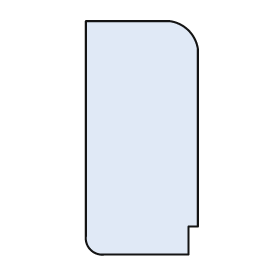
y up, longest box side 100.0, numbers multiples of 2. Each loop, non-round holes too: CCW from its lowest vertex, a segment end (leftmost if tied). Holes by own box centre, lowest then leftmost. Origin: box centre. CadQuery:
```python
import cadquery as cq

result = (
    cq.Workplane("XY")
    .moveTo(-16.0, -50.0)
    .lineTo(20.0, -50.0)
    .lineTo(20.0, -38.0)
    .lineTo(24.0, -38.0)
    .lineTo(24.0, 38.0)
    .threePointArc((20.0, 46.0), (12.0, 50.0))
    .lineTo(-24.0, 50.0)
    .lineTo(-24.0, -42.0)
    .threePointArc((-22.0, -48.0), (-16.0, -50.0))
    .close()
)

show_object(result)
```